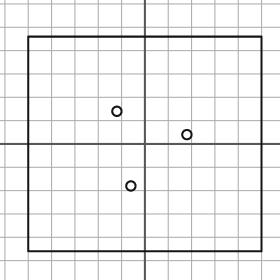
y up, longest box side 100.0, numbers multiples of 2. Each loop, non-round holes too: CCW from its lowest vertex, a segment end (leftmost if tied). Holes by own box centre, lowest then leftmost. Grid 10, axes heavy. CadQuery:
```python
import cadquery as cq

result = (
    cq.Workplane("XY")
    .moveTo(-50.0, -46.0)
    .lineTo(50.0, -46.0)
    .lineTo(50.0, 46.0)
    .lineTo(-50.0, 46.0)
    .close()
    .moveTo(-6.0, -18.0)
    .circle(2.0)
    .moveTo(18.0, 4.0)
    .circle(2.0)
    .moveTo(-12.0, 14.0)
    .circle(2.0)
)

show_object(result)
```